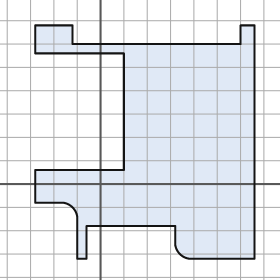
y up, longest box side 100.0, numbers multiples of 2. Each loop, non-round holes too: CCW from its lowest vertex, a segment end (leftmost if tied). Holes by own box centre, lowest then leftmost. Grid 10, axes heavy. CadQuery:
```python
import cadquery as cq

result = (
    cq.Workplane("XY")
    .moveTo(-10.0, -32.0)
    .lineTo(-6.0, -32.0)
    .lineTo(-6.0, -18.0)
    .lineTo(32.0, -18.0)
    .lineTo(32.0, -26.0)
    .threePointArc((34.0, -30.0), (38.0, -32.0))
    .lineTo(66.0, -32.0)
    .lineTo(66.0, 68.0)
    .lineTo(60.0, 68.0)
    .lineTo(60.0, 60.0)
    .lineTo(-12.0, 60.0)
    .lineTo(-12.0, 68.0)
    .lineTo(-28.0, 68.0)
    .lineTo(-28.0, 56.0)
    .lineTo(10.0, 56.0)
    .lineTo(10.0, 6.0)
    .lineTo(-28.0, 6.0)
    .lineTo(-28.0, -8.0)
    .lineTo(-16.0, -8.0)
    .threePointArc((-12.0, -10.0), (-10.0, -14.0))
    .close()
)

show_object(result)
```